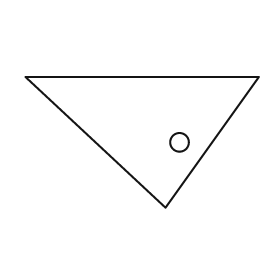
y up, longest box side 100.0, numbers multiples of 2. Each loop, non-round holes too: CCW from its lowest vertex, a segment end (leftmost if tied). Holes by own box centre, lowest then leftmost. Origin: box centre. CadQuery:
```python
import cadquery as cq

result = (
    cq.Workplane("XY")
    .moveTo(10.0, -28.0)
    .lineTo(50.0, 28.0)
    .lineTo(-50.0, 28.0)
    .close()
    .moveTo(16.0, 0.0)
    .circle(4.0)
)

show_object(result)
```